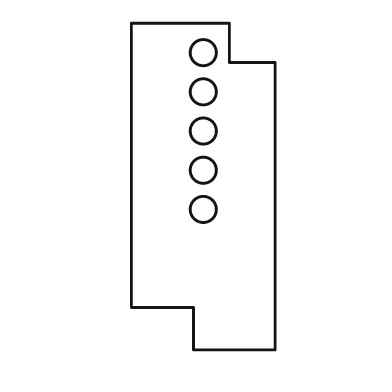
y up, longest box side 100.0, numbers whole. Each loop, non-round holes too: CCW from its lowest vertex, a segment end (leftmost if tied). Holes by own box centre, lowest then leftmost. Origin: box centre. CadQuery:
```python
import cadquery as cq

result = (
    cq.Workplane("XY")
    .moveTo(-3.0, -50.0)
    .lineTo(22.0, -50.0)
    .lineTo(22.0, 38.0)
    .lineTo(8.0, 38.0)
    .lineTo(8.0, 50.0)
    .lineTo(-22.0, 50.0)
    .lineTo(-22.0, -37.0)
    .lineTo(-3.0, -37.0)
    .close()
    .moveTo(0.0, -7.0)
    .circle(4.0)
    .moveTo(0.0, 5.0)
    .circle(4.0)
    .moveTo(0.0, 17.0)
    .circle(4.0)
    .moveTo(0.0, 29.0)
    .circle(4.0)
    .moveTo(0.0, 41.0)
    .circle(4.0)
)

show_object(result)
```